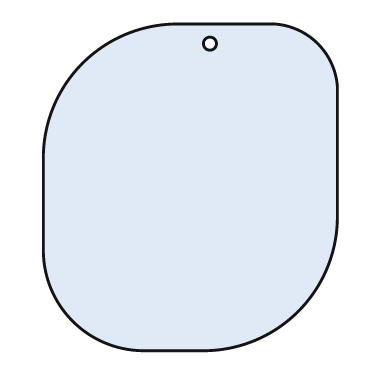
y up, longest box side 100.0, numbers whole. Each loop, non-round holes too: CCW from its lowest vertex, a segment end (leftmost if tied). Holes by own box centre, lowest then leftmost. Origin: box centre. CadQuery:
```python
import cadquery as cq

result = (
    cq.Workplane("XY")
    .moveTo(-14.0, -50.0)
    .lineTo(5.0, -50.0)
    .threePointArc((33.0, -38.0), (45.0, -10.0))
    .lineTo(45.0, 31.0)
    .threePointArc((39.0, 44.0), (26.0, 50.0))
    .lineTo(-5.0, 50.0)
    .threePointArc((-33.0, 38.0), (-45.0, 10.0))
    .lineTo(-45.0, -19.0)
    .threePointArc((-36.0, -41.0), (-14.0, -50.0))
    .close()
    .moveTo(6.0, 44.0)
    .circle(2.0)
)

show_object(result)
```